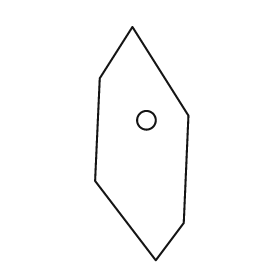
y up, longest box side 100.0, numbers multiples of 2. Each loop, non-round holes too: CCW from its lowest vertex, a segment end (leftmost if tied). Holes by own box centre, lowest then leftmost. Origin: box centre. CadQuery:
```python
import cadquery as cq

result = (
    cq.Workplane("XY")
    .moveTo(6.0, -50.0)
    .lineTo(18.0, -34.0)
    .lineTo(20.0, 12.0)
    .lineTo(-4.0, 50.0)
    .lineTo(-18.0, 28.0)
    .lineTo(-20.0, -16.0)
    .close()
    .moveTo(2.0, 10.0)
    .circle(4.0)
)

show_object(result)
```